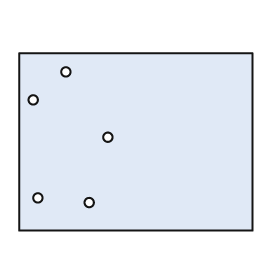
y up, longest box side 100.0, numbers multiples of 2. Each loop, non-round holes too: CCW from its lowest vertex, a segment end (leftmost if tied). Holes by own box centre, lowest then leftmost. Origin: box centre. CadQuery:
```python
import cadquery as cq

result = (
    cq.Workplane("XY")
    .moveTo(-50.0, -38.0)
    .lineTo(50.0, -38.0)
    .lineTo(50.0, 38.0)
    .lineTo(-50.0, 38.0)
    .close()
    .moveTo(-20.0, -26.0)
    .circle(2.0)
    .moveTo(-42.0, -24.0)
    .circle(2.0)
    .moveTo(-12.0, 2.0)
    .circle(2.0)
    .moveTo(-44.0, 18.0)
    .circle(2.0)
    .moveTo(-30.0, 30.0)
    .circle(2.0)
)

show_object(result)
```